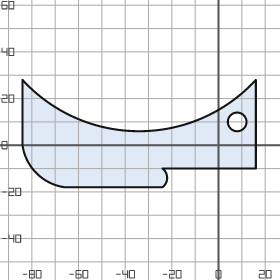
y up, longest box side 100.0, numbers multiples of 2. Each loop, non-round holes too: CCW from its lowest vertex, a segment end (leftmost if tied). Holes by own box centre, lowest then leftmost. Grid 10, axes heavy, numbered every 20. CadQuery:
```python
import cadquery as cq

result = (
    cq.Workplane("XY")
    .moveTo(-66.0, -18.0)
    .lineTo(-24.0, -18.0)
    .threePointArc((-22.0, -14.0), (-24.0, -10.0))
    .lineTo(16.0, -10.0)
    .lineTo(16.0, 28.0)
    .threePointArc((-34.0, 6.0), (-84.0, 28.0))
    .lineTo(-84.0, 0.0)
    .threePointArc((-78.0, -12.0), (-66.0, -18.0))
    .close()
    .moveTo(8.0, 10.0)
    .circle(4.0)
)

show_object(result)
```